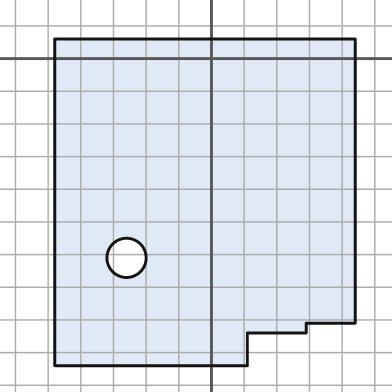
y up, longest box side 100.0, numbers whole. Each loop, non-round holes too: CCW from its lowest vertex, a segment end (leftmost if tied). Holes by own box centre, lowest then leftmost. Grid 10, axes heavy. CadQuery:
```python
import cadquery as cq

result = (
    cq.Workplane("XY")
    .moveTo(-48.0, -94.0)
    .lineTo(11.0, -94.0)
    .lineTo(11.0, -84.0)
    .lineTo(29.0, -84.0)
    .lineTo(29.0, -81.0)
    .lineTo(44.0, -81.0)
    .lineTo(44.0, 6.0)
    .lineTo(-48.0, 6.0)
    .close()
    .moveTo(-26.0, -61.0)
    .circle(6.0)
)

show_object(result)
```